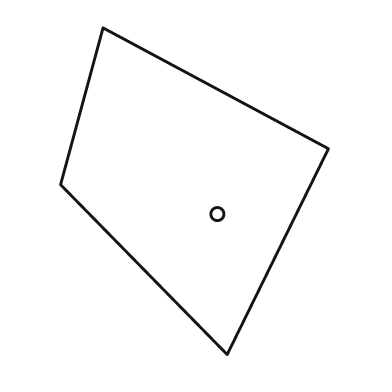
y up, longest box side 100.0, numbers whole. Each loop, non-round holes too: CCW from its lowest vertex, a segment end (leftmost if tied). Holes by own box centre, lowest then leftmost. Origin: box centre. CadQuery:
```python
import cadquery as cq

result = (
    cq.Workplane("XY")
    .moveTo(10.0, -50.0)
    .lineTo(41.0, 13.0)
    .lineTo(-28.0, 50.0)
    .lineTo(-41.0, 2.0)
    .close()
    .moveTo(7.0, -7.0)
    .circle(2.0)
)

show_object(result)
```